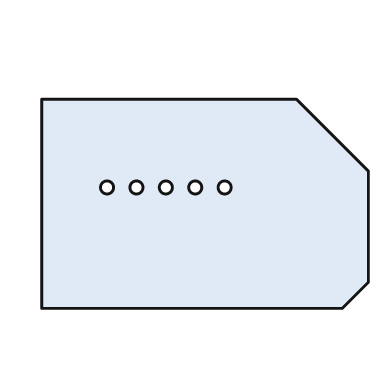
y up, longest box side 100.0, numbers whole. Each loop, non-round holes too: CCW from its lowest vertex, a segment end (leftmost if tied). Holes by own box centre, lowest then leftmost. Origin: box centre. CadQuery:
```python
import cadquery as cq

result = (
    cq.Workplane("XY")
    .moveTo(-50.0, -32.0)
    .lineTo(42.0, -32.0)
    .lineTo(50.0, -24.0)
    .lineTo(50.0, 10.0)
    .lineTo(28.0, 32.0)
    .lineTo(-50.0, 32.0)
    .close()
    .moveTo(-30.0, 5.0)
    .circle(2.0)
    .moveTo(-21.0, 5.0)
    .circle(2.0)
    .moveTo(-12.0, 5.0)
    .circle(2.0)
    .moveTo(-3.0, 5.0)
    .circle(2.0)
    .moveTo(6.0, 5.0)
    .circle(2.0)
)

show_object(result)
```